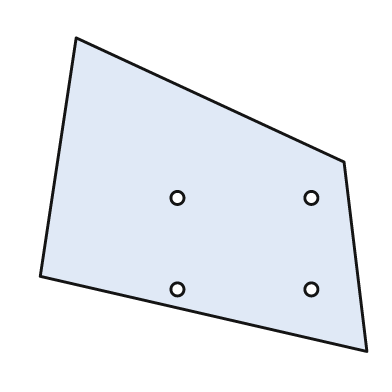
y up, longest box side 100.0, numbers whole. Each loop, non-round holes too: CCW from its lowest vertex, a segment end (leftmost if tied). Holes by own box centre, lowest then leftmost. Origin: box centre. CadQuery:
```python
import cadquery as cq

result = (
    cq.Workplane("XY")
    .moveTo(50.0, -48.0)
    .lineTo(43.0, 10.0)
    .lineTo(-39.0, 48.0)
    .lineTo(-50.0, -25.0)
    .close()
    .moveTo(-8.0, -29.0)
    .circle(2.0)
    .moveTo(33.0, -29.0)
    .circle(2.0)
    .moveTo(-8.0, -1.0)
    .circle(2.0)
    .moveTo(33.0, -1.0)
    .circle(2.0)
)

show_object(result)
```